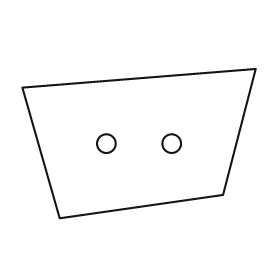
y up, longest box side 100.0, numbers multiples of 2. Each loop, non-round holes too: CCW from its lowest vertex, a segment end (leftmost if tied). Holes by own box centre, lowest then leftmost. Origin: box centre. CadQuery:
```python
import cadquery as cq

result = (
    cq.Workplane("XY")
    .moveTo(-34.0, -32.0)
    .lineTo(36.0, -22.0)
    .lineTo(50.0, 32.0)
    .lineTo(-50.0, 24.0)
    .close()
    .moveTo(-14.0, 0.0)
    .circle(4.0)
    .moveTo(14.0, 0.0)
    .circle(4.0)
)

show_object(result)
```